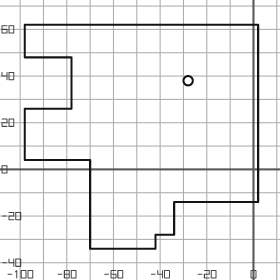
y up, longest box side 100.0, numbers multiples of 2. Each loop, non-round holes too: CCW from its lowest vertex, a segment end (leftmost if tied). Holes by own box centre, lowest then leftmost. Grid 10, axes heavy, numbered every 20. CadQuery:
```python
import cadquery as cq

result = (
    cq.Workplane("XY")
    .moveTo(-70.0, -34.0)
    .lineTo(-42.0, -34.0)
    .lineTo(-42.0, -28.0)
    .lineTo(-34.0, -28.0)
    .lineTo(-34.0, -14.0)
    .lineTo(2.0, -14.0)
    .lineTo(2.0, 62.0)
    .lineTo(-98.0, 62.0)
    .lineTo(-98.0, 48.0)
    .lineTo(-78.0, 48.0)
    .lineTo(-78.0, 26.0)
    .lineTo(-98.0, 26.0)
    .lineTo(-98.0, 4.0)
    .lineTo(-70.0, 4.0)
    .close()
    .moveTo(-28.0, 38.0)
    .circle(2.0)
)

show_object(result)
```